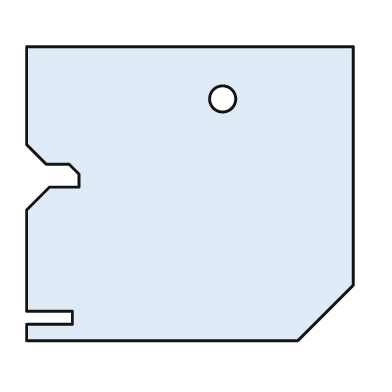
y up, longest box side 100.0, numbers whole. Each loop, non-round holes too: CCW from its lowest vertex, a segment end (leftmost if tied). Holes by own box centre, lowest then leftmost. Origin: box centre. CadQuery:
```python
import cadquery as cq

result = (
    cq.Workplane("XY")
    .moveTo(-50.0, -45.0)
    .lineTo(33.0, -45.0)
    .lineTo(50.0, -28.0)
    .lineTo(50.0, 45.0)
    .lineTo(-50.0, 45.0)
    .lineTo(-50.0, 15.0)
    .lineTo(-44.0, 9.0)
    .lineTo(-37.0, 9.0)
    .lineTo(-34.0, 6.0)
    .lineTo(-34.0, 2.0)
    .lineTo(-43.0, 2.0)
    .lineTo(-50.0, -5.0)
    .lineTo(-50.0, -36.0)
    .lineTo(-36.0, -36.0)
    .lineTo(-36.0, -40.0)
    .lineTo(-50.0, -40.0)
    .close()
    .moveTo(10.0, 29.0)
    .circle(4.0)
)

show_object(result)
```